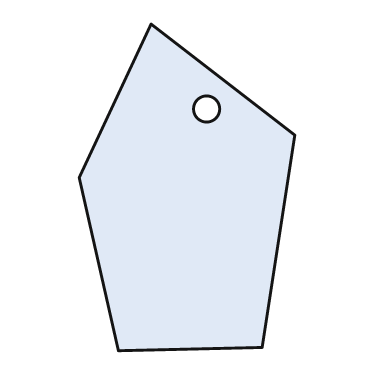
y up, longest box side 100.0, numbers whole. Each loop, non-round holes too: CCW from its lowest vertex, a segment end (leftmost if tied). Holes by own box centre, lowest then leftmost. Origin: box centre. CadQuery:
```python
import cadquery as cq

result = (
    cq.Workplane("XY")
    .moveTo(-21.0, -50.0)
    .lineTo(23.0, -49.0)
    .lineTo(33.0, 16.0)
    .lineTo(-11.0, 50.0)
    .lineTo(-33.0, 3.0)
    .close()
    .moveTo(6.0, 24.0)
    .circle(4.0)
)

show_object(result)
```